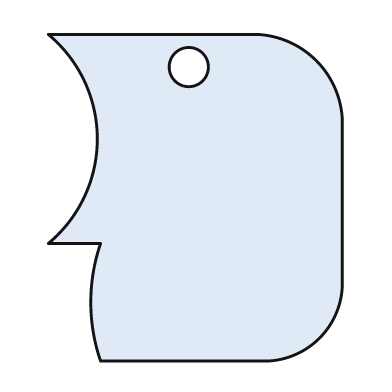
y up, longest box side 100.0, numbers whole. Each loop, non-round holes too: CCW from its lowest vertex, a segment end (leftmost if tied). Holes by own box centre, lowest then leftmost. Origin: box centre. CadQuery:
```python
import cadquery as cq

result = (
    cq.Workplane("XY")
    .moveTo(-29.0, -50.0)
    .lineTo(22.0, -50.0)
    .threePointArc((38.0, -43.0), (45.0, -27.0))
    .lineTo(45.0, 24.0)
    .threePointArc((37.0, 42.0), (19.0, 50.0))
    .lineTo(-45.0, 50.0)
    .threePointArc((-30.0, 18.0), (-45.0, -14.0))
    .lineTo(-29.0, -14.0)
    .threePointArc((-32.0, -32.0), (-29.0, -50.0))
    .close()
    .moveTo(-2.0, 40.0)
    .circle(6.0)
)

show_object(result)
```